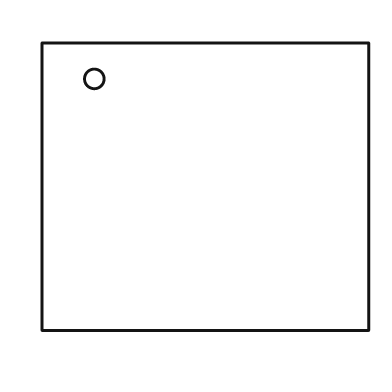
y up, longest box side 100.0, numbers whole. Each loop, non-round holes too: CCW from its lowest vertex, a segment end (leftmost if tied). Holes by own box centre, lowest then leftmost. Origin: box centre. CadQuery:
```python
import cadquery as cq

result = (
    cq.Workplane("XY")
    .moveTo(-50.0, -44.0)
    .lineTo(50.0, -44.0)
    .lineTo(50.0, 44.0)
    .lineTo(-50.0, 44.0)
    .close()
    .moveTo(-34.0, 33.0)
    .circle(3.0)
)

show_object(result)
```